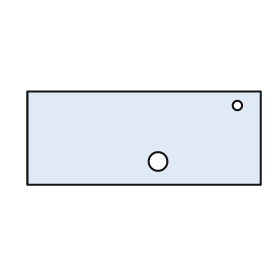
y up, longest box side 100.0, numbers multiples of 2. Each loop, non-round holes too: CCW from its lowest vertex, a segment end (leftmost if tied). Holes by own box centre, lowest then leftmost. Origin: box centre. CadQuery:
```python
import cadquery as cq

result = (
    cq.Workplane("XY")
    .moveTo(-50.0, -20.0)
    .lineTo(50.0, -20.0)
    .lineTo(50.0, 20.0)
    .lineTo(-50.0, 20.0)
    .close()
    .moveTo(6.0, -10.0)
    .circle(4.0)
    .moveTo(40.0, 14.0)
    .circle(2.0)
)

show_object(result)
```